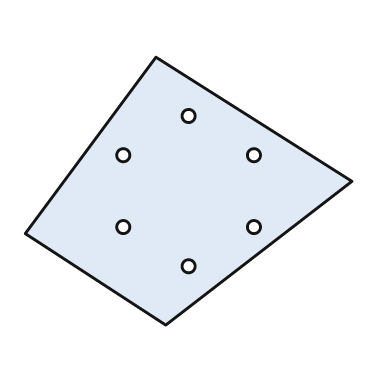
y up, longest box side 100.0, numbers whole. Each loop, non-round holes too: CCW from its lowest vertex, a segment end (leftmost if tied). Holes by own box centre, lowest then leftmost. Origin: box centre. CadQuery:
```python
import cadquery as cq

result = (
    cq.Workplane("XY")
    .moveTo(-7.0, -41.0)
    .lineTo(50.0, 3.0)
    .lineTo(-10.0, 41.0)
    .lineTo(-50.0, -13.0)
    .close()
    .moveTo(0.0, -23.0)
    .circle(2.0)
    .moveTo(-20.0, -11.0)
    .circle(2.0)
    .moveTo(20.0, -11.0)
    .circle(2.0)
    .moveTo(-20.0, 11.0)
    .circle(2.0)
    .moveTo(20.0, 11.0)
    .circle(2.0)
    .moveTo(0.0, 23.0)
    .circle(2.0)
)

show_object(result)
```